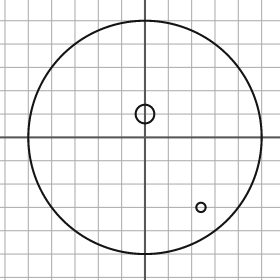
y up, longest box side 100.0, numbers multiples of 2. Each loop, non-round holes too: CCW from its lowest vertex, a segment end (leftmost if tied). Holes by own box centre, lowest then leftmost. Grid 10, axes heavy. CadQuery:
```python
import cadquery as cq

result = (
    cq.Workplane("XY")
    .moveTo(0.0, 0.0)
    .circle(50.0)
    .moveTo(24.0, -30.0)
    .circle(2.0)
    .moveTo(0.0, 10.0)
    .circle(4.0)
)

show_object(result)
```